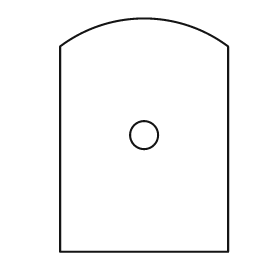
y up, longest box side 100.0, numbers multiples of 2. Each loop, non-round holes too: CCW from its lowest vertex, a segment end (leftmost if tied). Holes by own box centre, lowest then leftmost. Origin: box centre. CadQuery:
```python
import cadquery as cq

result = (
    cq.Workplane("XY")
    .moveTo(-36.0, -50.0)
    .lineTo(36.0, -50.0)
    .lineTo(36.0, 38.0)
    .threePointArc((0.0, 50.0), (-36.0, 38.0))
    .close()
    .moveTo(0.0, 0.0)
    .circle(6.0)
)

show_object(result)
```